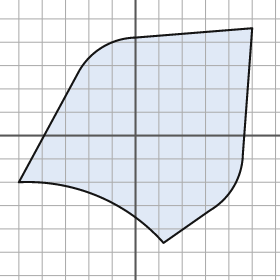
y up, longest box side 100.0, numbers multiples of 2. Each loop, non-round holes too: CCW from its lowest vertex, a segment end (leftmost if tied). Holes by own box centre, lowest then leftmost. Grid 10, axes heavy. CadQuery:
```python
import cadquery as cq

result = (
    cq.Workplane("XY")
    .moveTo(12.0, -46.0)
    .lineTo(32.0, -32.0)
    .threePointArc((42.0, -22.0), (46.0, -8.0))
    .lineTo(50.0, 46.0)
    .lineTo(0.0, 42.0)
    .threePointArc((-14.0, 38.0), (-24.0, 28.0))
    .lineTo(-50.0, -20.0)
    .threePointArc((-16.0, -26.0), (12.0, -46.0))
    .close()
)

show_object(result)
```